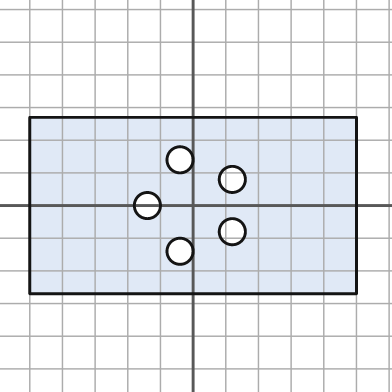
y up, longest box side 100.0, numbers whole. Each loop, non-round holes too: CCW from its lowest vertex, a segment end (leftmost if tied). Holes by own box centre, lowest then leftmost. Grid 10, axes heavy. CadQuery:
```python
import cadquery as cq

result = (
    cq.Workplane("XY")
    .moveTo(-50.0, -27.0)
    .lineTo(50.0, -27.0)
    .lineTo(50.0, 27.0)
    .lineTo(-50.0, 27.0)
    .close()
    .moveTo(-4.0, -14.0)
    .circle(4.0)
    .moveTo(12.0, -8.0)
    .circle(4.0)
    .moveTo(-14.0, 0.0)
    .circle(4.0)
    .moveTo(12.0, 8.0)
    .circle(4.0)
    .moveTo(-4.0, 14.0)
    .circle(4.0)
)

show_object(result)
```